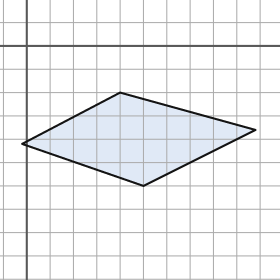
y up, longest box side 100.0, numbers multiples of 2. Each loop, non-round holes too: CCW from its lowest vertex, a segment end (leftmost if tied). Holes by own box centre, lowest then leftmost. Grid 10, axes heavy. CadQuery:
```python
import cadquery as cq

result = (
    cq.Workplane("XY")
    .moveTo(50.0, -60.0)
    .lineTo(98.0, -36.0)
    .lineTo(40.0, -20.0)
    .lineTo(-2.0, -42.0)
    .close()
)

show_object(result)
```